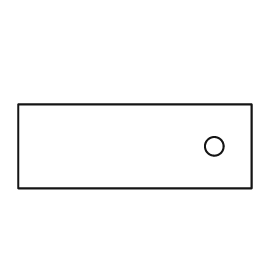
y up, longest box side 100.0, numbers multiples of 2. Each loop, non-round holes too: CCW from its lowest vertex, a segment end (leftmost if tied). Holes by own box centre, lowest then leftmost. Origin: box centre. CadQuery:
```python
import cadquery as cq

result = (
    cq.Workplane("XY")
    .moveTo(-50.0, -18.0)
    .lineTo(50.0, -18.0)
    .lineTo(50.0, 18.0)
    .lineTo(-50.0, 18.0)
    .close()
    .moveTo(34.0, 0.0)
    .circle(4.0)
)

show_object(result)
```